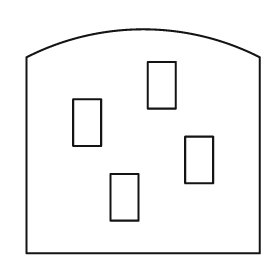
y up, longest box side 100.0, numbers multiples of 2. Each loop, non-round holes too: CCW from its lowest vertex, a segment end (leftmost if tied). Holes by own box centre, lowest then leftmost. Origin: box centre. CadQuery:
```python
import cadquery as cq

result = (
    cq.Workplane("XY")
    .moveTo(-50.0, -48.0)
    .lineTo(50.0, -48.0)
    .lineTo(50.0, 36.0)
    .threePointArc((0.0, 48.0), (-50.0, 36.0))
    .close()
    .moveTo(-14.0, -34.0)
    .lineTo(-2.0, -34.0)
    .lineTo(-2.0, -14.0)
    .lineTo(-14.0, -14.0)
    .close()
    .moveTo(18.0, -18.0)
    .lineTo(30.0, -18.0)
    .lineTo(30.0, 2.0)
    .lineTo(18.0, 2.0)
    .close()
    .moveTo(-30.0, -2.0)
    .lineTo(-18.0, -2.0)
    .lineTo(-18.0, 18.0)
    .lineTo(-30.0, 18.0)
    .close()
    .moveTo(2.0, 14.0)
    .lineTo(14.0, 14.0)
    .lineTo(14.0, 34.0)
    .lineTo(2.0, 34.0)
    .close()
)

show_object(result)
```